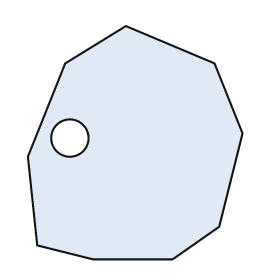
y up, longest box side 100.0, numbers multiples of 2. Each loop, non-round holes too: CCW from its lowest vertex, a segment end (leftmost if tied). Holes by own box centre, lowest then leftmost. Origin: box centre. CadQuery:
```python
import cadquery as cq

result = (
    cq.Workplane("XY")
    .moveTo(-18.0, -50.0)
    .lineTo(16.0, -50.0)
    .lineTo(36.0, -36.0)
    .lineTo(46.0, 4.0)
    .lineTo(34.0, 34.0)
    .lineTo(-4.0, 50.0)
    .lineTo(-30.0, 34.0)
    .lineTo(-46.0, -6.0)
    .lineTo(-42.0, -44.0)
    .close()
    .moveTo(-28.0, 2.0)
    .circle(8.0)
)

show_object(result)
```